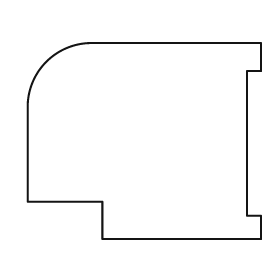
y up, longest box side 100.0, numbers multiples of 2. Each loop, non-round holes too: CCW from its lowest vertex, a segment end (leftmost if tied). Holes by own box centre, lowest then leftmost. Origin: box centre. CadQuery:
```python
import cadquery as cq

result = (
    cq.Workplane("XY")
    .moveTo(-18.0, -42.0)
    .lineTo(50.0, -42.0)
    .lineTo(50.0, -32.0)
    .lineTo(44.0, -32.0)
    .lineTo(44.0, 30.0)
    .lineTo(50.0, 30.0)
    .lineTo(50.0, 42.0)
    .lineTo(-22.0, 42.0)
    .threePointArc((-42.0, 34.0), (-50.0, 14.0))
    .lineTo(-50.0, -26.0)
    .lineTo(-18.0, -26.0)
    .close()
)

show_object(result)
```